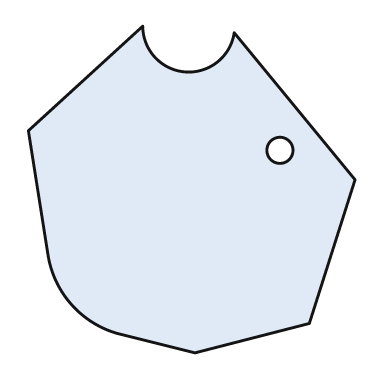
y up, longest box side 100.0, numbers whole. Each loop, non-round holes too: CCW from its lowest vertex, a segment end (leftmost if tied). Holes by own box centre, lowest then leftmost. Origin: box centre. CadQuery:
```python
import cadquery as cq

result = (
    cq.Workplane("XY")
    .moveTo(1.0, -50.0)
    .lineTo(36.0, -41.0)
    .lineTo(50.0, 3.0)
    .lineTo(13.0, 48.0)
    .threePointArc((-2.0, 36.0), (-15.0, 50.0))
    .lineTo(-50.0, 18.0)
    .lineTo(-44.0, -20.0)
    .threePointArc((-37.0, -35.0), (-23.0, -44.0))
    .close()
    .moveTo(27.0, 12.0)
    .circle(4.0)
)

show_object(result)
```